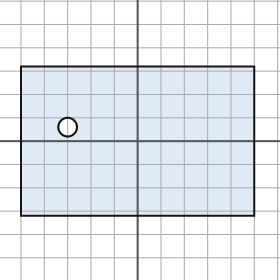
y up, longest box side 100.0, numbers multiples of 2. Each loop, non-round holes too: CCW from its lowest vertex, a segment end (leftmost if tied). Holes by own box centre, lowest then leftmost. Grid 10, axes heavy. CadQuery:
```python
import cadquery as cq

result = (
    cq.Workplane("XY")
    .moveTo(-50.0, -32.0)
    .lineTo(50.0, -32.0)
    .lineTo(50.0, 32.0)
    .lineTo(-50.0, 32.0)
    .close()
    .moveTo(-30.0, 6.0)
    .circle(4.0)
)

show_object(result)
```